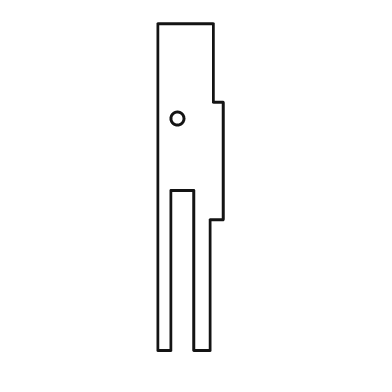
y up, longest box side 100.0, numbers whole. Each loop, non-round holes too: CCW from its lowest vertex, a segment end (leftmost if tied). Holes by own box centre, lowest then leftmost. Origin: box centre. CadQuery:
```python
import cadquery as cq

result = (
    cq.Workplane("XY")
    .moveTo(-10.0, -50.0)
    .lineTo(-6.0, -50.0)
    .lineTo(-6.0, -1.0)
    .lineTo(1.0, -1.0)
    .lineTo(1.0, -50.0)
    .lineTo(6.0, -50.0)
    .lineTo(6.0, -10.0)
    .lineTo(10.0, -10.0)
    .lineTo(10.0, 26.0)
    .lineTo(7.0, 26.0)
    .lineTo(7.0, 50.0)
    .lineTo(-10.0, 50.0)
    .close()
    .moveTo(-4.0, 21.0)
    .circle(2.0)
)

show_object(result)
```